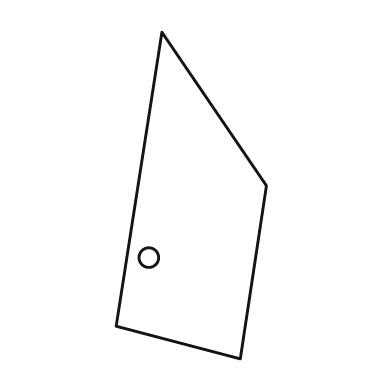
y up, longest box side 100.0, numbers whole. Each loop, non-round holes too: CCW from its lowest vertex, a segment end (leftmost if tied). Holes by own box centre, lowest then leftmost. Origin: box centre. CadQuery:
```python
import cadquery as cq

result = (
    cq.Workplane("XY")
    .moveTo(15.0, -50.0)
    .lineTo(23.0, 3.0)
    .lineTo(-9.0, 50.0)
    .lineTo(-23.0, -40.0)
    .close()
    .moveTo(-13.0, -19.0)
    .circle(3.0)
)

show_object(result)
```